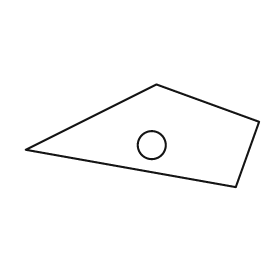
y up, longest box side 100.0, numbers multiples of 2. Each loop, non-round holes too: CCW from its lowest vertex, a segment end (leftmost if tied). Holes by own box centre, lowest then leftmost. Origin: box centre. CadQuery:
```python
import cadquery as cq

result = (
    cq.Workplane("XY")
    .moveTo(40.0, -22.0)
    .lineTo(50.0, 6.0)
    .lineTo(6.0, 22.0)
    .lineTo(-50.0, -6.0)
    .close()
    .moveTo(4.0, -4.0)
    .circle(6.0)
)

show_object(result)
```